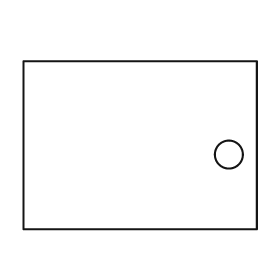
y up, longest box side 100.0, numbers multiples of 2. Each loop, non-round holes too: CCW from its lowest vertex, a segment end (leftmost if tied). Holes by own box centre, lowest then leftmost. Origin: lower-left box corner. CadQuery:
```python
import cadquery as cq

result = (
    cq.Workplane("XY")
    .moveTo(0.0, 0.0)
    .lineTo(100.0, 0.0)
    .lineTo(100.0, 72.0)
    .lineTo(0.0, 72.0)
    .close()
    .moveTo(88.0, 32.0)
    .circle(6.0)
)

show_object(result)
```